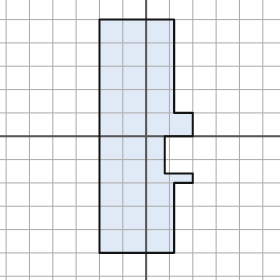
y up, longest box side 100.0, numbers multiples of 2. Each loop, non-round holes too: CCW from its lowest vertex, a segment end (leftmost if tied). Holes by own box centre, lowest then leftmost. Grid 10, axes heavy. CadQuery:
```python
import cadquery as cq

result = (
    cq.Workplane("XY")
    .moveTo(-20.0, -50.0)
    .lineTo(12.0, -50.0)
    .lineTo(12.0, -20.0)
    .lineTo(20.0, -20.0)
    .lineTo(20.0, -16.0)
    .lineTo(8.0, -16.0)
    .lineTo(8.0, 0.0)
    .lineTo(20.0, 0.0)
    .lineTo(20.0, 10.0)
    .lineTo(12.0, 10.0)
    .lineTo(12.0, 50.0)
    .lineTo(-20.0, 50.0)
    .close()
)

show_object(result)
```